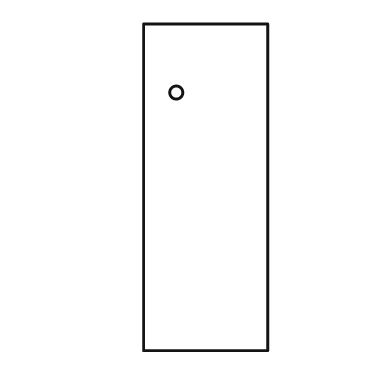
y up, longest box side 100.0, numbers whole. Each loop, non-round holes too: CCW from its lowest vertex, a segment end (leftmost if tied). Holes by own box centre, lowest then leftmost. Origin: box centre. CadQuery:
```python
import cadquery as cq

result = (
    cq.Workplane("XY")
    .moveTo(-19.0, -50.0)
    .lineTo(19.0, -50.0)
    .lineTo(19.0, 50.0)
    .lineTo(-19.0, 50.0)
    .close()
    .moveTo(-9.0, 29.0)
    .circle(2.0)
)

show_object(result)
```